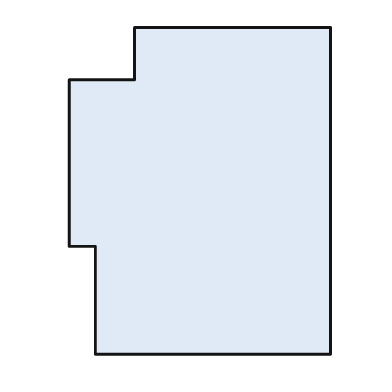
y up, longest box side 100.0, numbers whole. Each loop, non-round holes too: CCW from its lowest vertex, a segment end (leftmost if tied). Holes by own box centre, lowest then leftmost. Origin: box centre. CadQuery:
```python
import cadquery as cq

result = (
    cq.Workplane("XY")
    .moveTo(-32.0, -50.0)
    .lineTo(40.0, -50.0)
    .lineTo(40.0, 50.0)
    .lineTo(-20.0, 50.0)
    .lineTo(-20.0, 34.0)
    .lineTo(-40.0, 34.0)
    .lineTo(-40.0, -17.0)
    .lineTo(-32.0, -17.0)
    .close()
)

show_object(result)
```